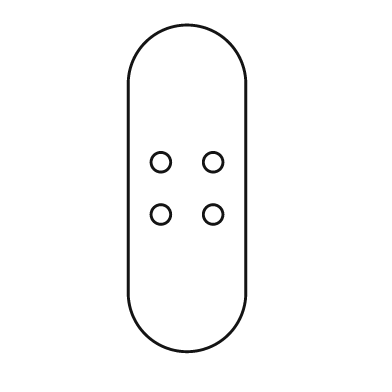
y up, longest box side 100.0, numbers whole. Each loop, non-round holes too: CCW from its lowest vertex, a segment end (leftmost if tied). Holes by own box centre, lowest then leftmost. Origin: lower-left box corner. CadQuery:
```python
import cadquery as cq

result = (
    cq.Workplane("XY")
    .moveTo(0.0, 18.0)
    .threePointArc((18.0, 0.0), (36.0, 18.0))
    .lineTo(36.0, 82.0)
    .threePointArc((18.0, 100.0), (0.0, 82.0))
    .close()
    .moveTo(10.0, 42.0)
    .circle(3.0)
    .moveTo(26.0, 42.0)
    .circle(3.0)
    .moveTo(10.0, 58.0)
    .circle(3.0)
    .moveTo(26.0, 58.0)
    .circle(3.0)
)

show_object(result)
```